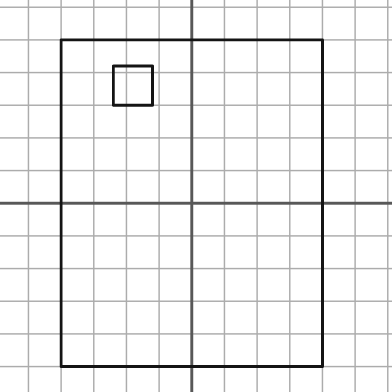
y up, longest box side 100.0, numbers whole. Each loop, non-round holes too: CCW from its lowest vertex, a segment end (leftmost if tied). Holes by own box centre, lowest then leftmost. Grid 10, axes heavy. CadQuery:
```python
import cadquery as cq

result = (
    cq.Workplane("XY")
    .moveTo(-40.0, -50.0)
    .lineTo(40.0, -50.0)
    .lineTo(40.0, 50.0)
    .lineTo(-40.0, 50.0)
    .close()
    .moveTo(-24.0, 30.0)
    .lineTo(-12.0, 30.0)
    .lineTo(-12.0, 42.0)
    .lineTo(-24.0, 42.0)
    .close()
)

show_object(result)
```